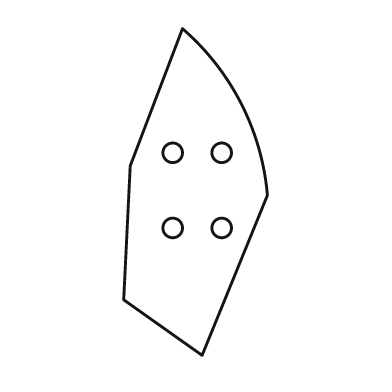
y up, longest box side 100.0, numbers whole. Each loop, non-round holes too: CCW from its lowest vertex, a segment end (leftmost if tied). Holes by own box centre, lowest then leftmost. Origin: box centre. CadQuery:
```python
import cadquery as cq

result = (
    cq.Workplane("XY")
    .moveTo(2.0, -50.0)
    .lineTo(22.0, -1.0)
    .threePointArc((14.0, 27.0), (-4.0, 50.0))
    .lineTo(-20.0, 8.0)
    .lineTo(-22.0, -33.0)
    .close()
    .moveTo(-7.0, -11.0)
    .circle(3.0)
    .moveTo(8.0, -11.0)
    .circle(3.0)
    .moveTo(-7.0, 12.0)
    .circle(3.0)
    .moveTo(8.0, 12.0)
    .circle(3.0)
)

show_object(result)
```